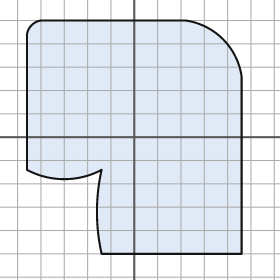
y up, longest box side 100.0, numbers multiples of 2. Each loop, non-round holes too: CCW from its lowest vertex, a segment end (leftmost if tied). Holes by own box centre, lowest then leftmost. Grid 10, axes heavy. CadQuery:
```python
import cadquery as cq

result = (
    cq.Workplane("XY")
    .moveTo(-14.0, -50.0)
    .lineTo(46.0, -50.0)
    .lineTo(46.0, 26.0)
    .threePointArc((38.0, 42.0), (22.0, 50.0))
    .lineTo(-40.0, 50.0)
    .threePointArc((-44.0, 48.0), (-46.0, 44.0))
    .lineTo(-46.0, -14.0)
    .threePointArc((-30.0, -18.0), (-14.0, -14.0))
    .threePointArc((-16.0, -32.0), (-14.0, -50.0))
    .close()
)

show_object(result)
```